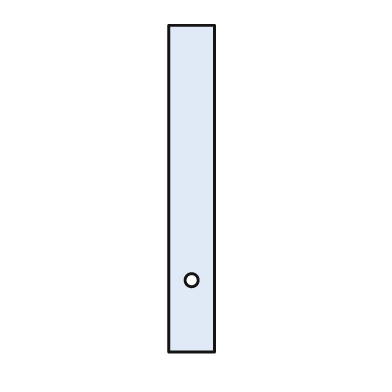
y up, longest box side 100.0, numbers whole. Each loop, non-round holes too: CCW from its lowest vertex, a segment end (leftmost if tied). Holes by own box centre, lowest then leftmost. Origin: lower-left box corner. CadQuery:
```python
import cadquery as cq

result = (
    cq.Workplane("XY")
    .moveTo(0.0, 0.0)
    .lineTo(14.0, 0.0)
    .lineTo(14.0, 100.0)
    .lineTo(0.0, 100.0)
    .close()
    .moveTo(7.0, 22.0)
    .circle(2.0)
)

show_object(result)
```